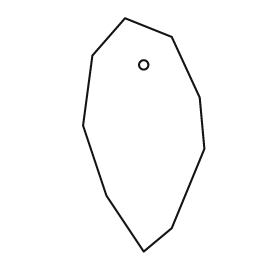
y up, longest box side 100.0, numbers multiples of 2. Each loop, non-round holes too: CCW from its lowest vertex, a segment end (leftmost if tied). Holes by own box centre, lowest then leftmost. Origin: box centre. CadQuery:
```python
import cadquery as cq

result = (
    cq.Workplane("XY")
    .moveTo(0.0, -50.0)
    .lineTo(12.0, -40.0)
    .lineTo(26.0, -6.0)
    .lineTo(24.0, 16.0)
    .lineTo(12.0, 42.0)
    .lineTo(-8.0, 50.0)
    .lineTo(-22.0, 34.0)
    .lineTo(-26.0, 4.0)
    .lineTo(-16.0, -26.0)
    .close()
    .moveTo(0.0, 30.0)
    .circle(2.0)
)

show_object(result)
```